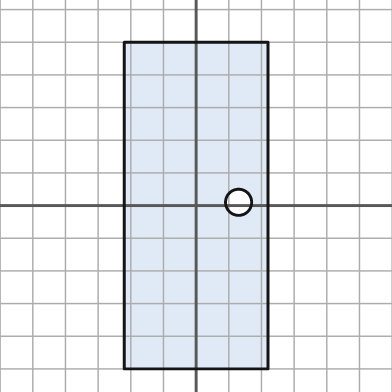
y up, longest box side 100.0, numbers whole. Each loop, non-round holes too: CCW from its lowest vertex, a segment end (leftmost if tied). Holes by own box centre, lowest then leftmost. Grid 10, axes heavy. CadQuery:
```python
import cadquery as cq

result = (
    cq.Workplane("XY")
    .moveTo(-22.0, -50.0)
    .lineTo(22.0, -50.0)
    .lineTo(22.0, 50.0)
    .lineTo(-22.0, 50.0)
    .close()
    .moveTo(13.0, 1.0)
    .circle(4.0)
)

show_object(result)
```